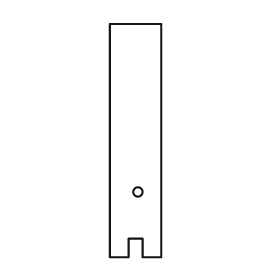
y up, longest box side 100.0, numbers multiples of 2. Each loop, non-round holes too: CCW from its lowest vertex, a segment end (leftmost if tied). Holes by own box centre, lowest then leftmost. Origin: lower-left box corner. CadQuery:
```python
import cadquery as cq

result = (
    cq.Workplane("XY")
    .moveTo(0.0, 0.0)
    .lineTo(8.0, 0.0)
    .lineTo(8.0, 8.0)
    .lineTo(14.0, 8.0)
    .lineTo(14.0, 0.0)
    .lineTo(22.0, 0.0)
    .lineTo(22.0, 100.0)
    .lineTo(0.0, 100.0)
    .close()
    .moveTo(12.0, 28.0)
    .circle(2.0)
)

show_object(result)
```